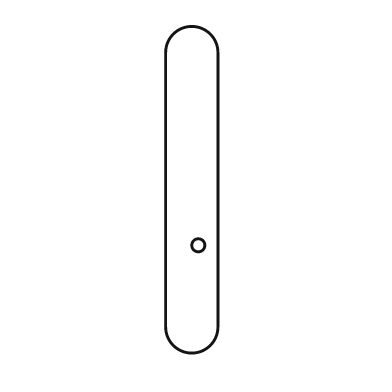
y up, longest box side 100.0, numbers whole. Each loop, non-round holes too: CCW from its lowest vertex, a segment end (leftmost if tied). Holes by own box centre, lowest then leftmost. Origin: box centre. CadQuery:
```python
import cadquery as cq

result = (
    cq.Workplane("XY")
    .moveTo(-8.0, -42.0)
    .threePointArc((0.0, -50.0), (8.0, -42.0))
    .lineTo(8.0, 42.0)
    .threePointArc((0.0, 50.0), (-8.0, 42.0))
    .close()
    .moveTo(2.0, -17.0)
    .circle(2.0)
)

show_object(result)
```